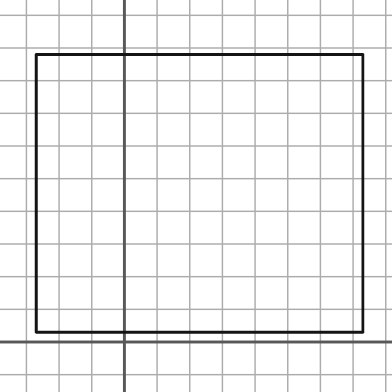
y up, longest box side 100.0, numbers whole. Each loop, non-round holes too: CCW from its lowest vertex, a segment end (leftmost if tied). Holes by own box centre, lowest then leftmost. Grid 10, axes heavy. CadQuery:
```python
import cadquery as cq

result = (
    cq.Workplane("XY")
    .moveTo(-27.0, 3.0)
    .lineTo(73.0, 3.0)
    .lineTo(73.0, 88.0)
    .lineTo(-27.0, 88.0)
    .close()
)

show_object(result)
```